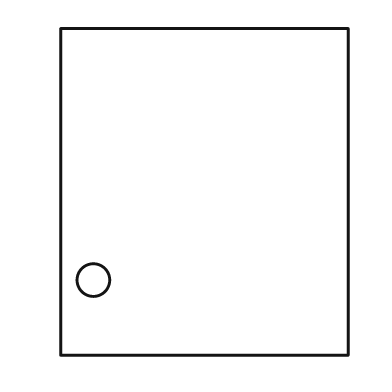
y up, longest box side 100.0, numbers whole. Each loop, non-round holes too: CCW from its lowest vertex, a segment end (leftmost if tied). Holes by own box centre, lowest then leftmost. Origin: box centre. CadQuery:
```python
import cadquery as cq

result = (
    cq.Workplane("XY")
    .moveTo(-44.0, -50.0)
    .lineTo(44.0, -50.0)
    .lineTo(44.0, 50.0)
    .lineTo(-44.0, 50.0)
    .close()
    .moveTo(-34.0, -27.0)
    .circle(5.0)
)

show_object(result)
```